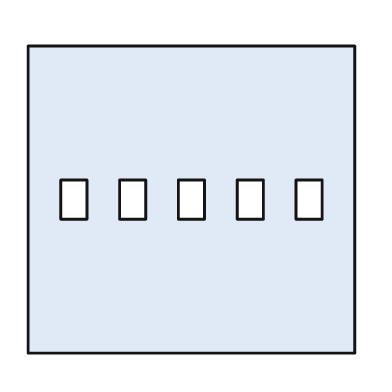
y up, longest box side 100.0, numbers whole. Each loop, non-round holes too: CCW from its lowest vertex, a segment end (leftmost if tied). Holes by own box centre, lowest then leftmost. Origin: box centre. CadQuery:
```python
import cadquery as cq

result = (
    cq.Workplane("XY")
    .moveTo(-50.0, -47.0)
    .lineTo(50.0, -47.0)
    .lineTo(50.0, 47.0)
    .lineTo(-50.0, 47.0)
    .close()
    .moveTo(-40.0, -6.0)
    .lineTo(-32.0, -6.0)
    .lineTo(-32.0, 6.0)
    .lineTo(-40.0, 6.0)
    .close()
    .moveTo(-22.0, -6.0)
    .lineTo(-14.0, -6.0)
    .lineTo(-14.0, 6.0)
    .lineTo(-22.0, 6.0)
    .close()
    .moveTo(-4.0, -6.0)
    .lineTo(4.0, -6.0)
    .lineTo(4.0, 6.0)
    .lineTo(-4.0, 6.0)
    .close()
    .moveTo(14.0, -6.0)
    .lineTo(22.0, -6.0)
    .lineTo(22.0, 6.0)
    .lineTo(14.0, 6.0)
    .close()
    .moveTo(32.0, -6.0)
    .lineTo(40.0, -6.0)
    .lineTo(40.0, 6.0)
    .lineTo(32.0, 6.0)
    .close()
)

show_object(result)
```